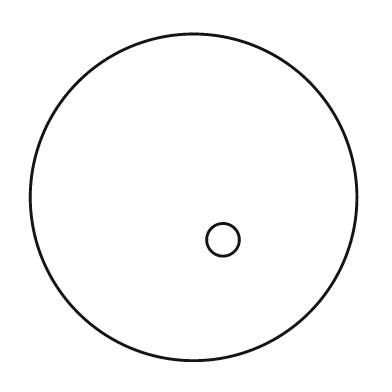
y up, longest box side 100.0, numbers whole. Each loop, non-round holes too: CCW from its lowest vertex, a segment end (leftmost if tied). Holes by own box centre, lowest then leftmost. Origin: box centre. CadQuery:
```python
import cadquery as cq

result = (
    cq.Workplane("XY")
    .moveTo(0.0, 0.0)
    .circle(50.0)
    .moveTo(9.0, -13.0)
    .circle(5.0)
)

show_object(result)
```